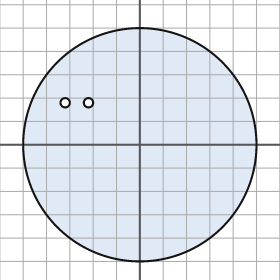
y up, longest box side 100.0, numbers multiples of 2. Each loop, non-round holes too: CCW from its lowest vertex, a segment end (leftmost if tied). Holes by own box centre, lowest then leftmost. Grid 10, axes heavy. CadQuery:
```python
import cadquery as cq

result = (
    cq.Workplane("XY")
    .moveTo(0.0, 0.0)
    .circle(50.0)
    .moveTo(-32.0, 18.0)
    .circle(2.0)
    .moveTo(-22.0, 18.0)
    .circle(2.0)
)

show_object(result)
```